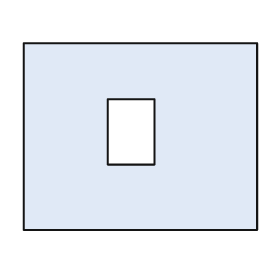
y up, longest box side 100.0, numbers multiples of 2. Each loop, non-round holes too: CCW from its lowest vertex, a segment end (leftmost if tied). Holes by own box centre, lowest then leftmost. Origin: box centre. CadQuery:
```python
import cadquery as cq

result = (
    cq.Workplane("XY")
    .moveTo(-50.0, -40.0)
    .lineTo(50.0, -40.0)
    .lineTo(50.0, 40.0)
    .lineTo(-50.0, 40.0)
    .close()
    .moveTo(-14.0, -12.0)
    .lineTo(6.0, -12.0)
    .lineTo(6.0, 16.0)
    .lineTo(-14.0, 16.0)
    .close()
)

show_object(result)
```